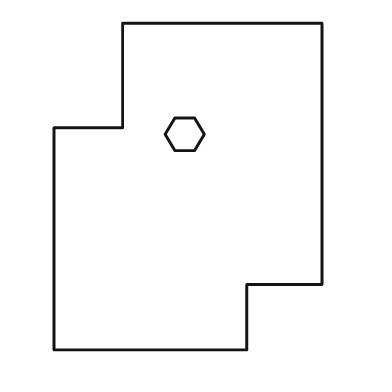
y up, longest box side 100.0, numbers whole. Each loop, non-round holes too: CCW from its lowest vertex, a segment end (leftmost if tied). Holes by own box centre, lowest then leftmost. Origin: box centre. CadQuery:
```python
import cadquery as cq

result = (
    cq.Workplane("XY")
    .moveTo(-41.0, -50.0)
    .lineTo(18.0, -50.0)
    .lineTo(18.0, -30.0)
    .lineTo(41.0, -30.0)
    .lineTo(41.0, 50.0)
    .lineTo(-20.0, 50.0)
    .lineTo(-20.0, 18.0)
    .lineTo(-41.0, 18.0)
    .close()
    .moveTo(-4.0, 11.0)
    .lineTo(2.0, 11.0)
    .lineTo(5.0, 16.0)
    .lineTo(2.0, 21.0)
    .lineTo(-4.0, 21.0)
    .lineTo(-7.0, 16.0)
    .close()
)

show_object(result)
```